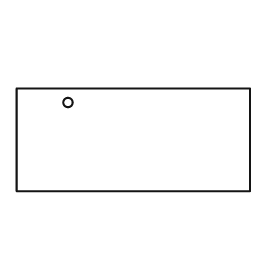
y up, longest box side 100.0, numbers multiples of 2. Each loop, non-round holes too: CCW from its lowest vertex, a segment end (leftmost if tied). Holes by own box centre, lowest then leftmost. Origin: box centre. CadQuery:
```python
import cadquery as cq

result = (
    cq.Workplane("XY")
    .moveTo(-50.0, -22.0)
    .lineTo(50.0, -22.0)
    .lineTo(50.0, 22.0)
    .lineTo(-50.0, 22.0)
    .close()
    .moveTo(-28.0, 16.0)
    .circle(2.0)
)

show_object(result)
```